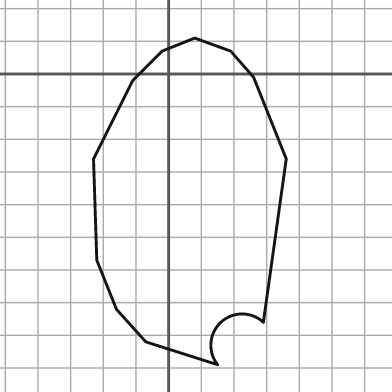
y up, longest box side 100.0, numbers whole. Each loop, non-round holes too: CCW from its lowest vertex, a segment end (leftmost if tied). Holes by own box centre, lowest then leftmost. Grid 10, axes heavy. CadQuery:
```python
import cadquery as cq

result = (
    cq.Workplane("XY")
    .moveTo(15.0, -89.0)
    .threePointArc((16.0, -76.0), (29.0, -76.0))
    .lineTo(36.0, -26.0)
    .lineTo(26.0, -1.0)
    .lineTo(19.0, 7.0)
    .lineTo(8.0, 11.0)
    .lineTo(-2.0, 7.0)
    .lineTo(-11.0, -2.0)
    .lineTo(-23.0, -26.0)
    .lineTo(-22.0, -57.0)
    .lineTo(-16.0, -72.0)
    .lineTo(-7.0, -82.0)
    .close()
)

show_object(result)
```